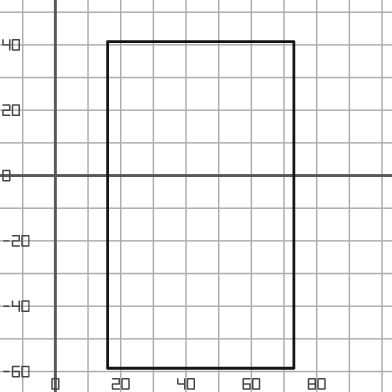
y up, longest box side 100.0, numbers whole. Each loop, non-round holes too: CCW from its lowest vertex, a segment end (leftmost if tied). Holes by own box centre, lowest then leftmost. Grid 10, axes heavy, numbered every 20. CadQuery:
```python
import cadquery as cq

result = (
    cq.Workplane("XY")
    .moveTo(16.0, -59.0)
    .lineTo(73.0, -59.0)
    .lineTo(73.0, 41.0)
    .lineTo(16.0, 41.0)
    .close()
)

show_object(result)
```